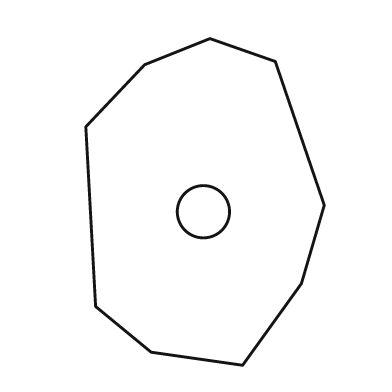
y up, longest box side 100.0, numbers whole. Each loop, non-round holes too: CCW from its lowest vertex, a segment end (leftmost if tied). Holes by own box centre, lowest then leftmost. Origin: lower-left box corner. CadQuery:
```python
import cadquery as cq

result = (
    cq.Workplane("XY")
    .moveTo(48.0, 0.0)
    .lineTo(66.0, 25.0)
    .lineTo(73.0, 49.0)
    .lineTo(58.0, 93.0)
    .lineTo(38.0, 100.0)
    .lineTo(18.0, 92.0)
    .lineTo(0.0, 73.0)
    .lineTo(3.0, 18.0)
    .lineTo(20.0, 4.0)
    .close()
    .moveTo(36.0, 47.0)
    .circle(8.0)
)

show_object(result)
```